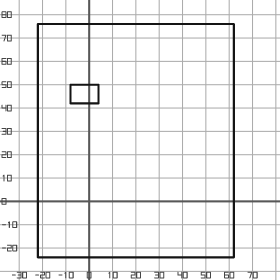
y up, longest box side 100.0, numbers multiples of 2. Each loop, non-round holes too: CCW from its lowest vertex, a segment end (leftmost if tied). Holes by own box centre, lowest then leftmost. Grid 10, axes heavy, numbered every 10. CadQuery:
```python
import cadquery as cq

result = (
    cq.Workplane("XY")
    .moveTo(-22.0, -24.0)
    .lineTo(62.0, -24.0)
    .lineTo(62.0, 76.0)
    .lineTo(-22.0, 76.0)
    .close()
    .moveTo(-8.0, 42.0)
    .lineTo(4.0, 42.0)
    .lineTo(4.0, 50.0)
    .lineTo(-8.0, 50.0)
    .close()
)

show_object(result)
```